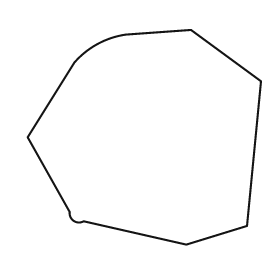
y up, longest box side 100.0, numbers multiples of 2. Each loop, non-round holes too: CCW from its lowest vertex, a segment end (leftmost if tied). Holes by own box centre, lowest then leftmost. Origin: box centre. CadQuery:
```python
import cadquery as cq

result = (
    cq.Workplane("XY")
    .moveTo(18.0, -46.0)
    .lineTo(44.0, -38.0)
    .lineTo(50.0, 24.0)
    .lineTo(20.0, 46.0)
    .lineTo(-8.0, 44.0)
    .threePointArc((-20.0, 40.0), (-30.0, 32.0))
    .lineTo(-50.0, 0.0)
    .lineTo(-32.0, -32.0)
    .threePointArc((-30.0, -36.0), (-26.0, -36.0))
    .close()
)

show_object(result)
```